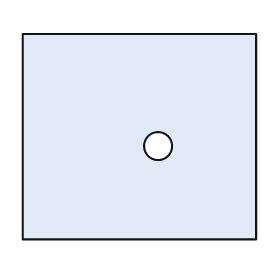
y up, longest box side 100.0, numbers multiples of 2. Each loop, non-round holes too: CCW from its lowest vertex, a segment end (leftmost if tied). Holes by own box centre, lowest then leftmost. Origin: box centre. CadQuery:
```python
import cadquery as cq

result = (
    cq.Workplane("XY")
    .moveTo(-50.0, -44.0)
    .lineTo(50.0, -44.0)
    .lineTo(50.0, 44.0)
    .lineTo(-50.0, 44.0)
    .close()
    .moveTo(8.0, -4.0)
    .circle(6.0)
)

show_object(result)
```